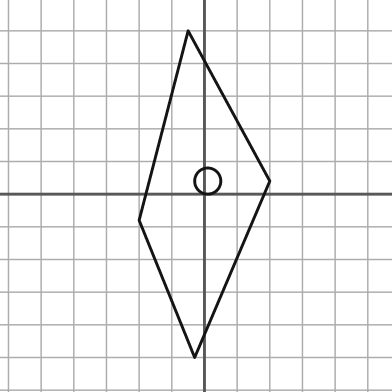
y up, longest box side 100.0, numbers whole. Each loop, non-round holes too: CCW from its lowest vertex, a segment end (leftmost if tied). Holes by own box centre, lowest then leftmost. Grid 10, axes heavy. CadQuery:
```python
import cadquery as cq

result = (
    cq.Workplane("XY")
    .moveTo(-3.0, -50.0)
    .lineTo(20.0, 4.0)
    .lineTo(-5.0, 50.0)
    .lineTo(-20.0, -8.0)
    .close()
    .moveTo(1.0, 4.0)
    .circle(4.0)
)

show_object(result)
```